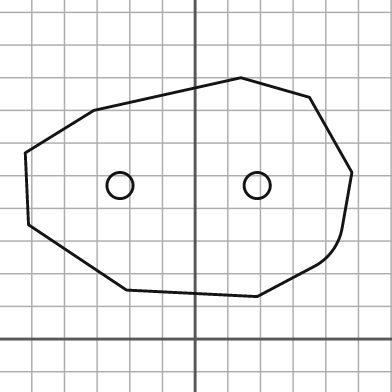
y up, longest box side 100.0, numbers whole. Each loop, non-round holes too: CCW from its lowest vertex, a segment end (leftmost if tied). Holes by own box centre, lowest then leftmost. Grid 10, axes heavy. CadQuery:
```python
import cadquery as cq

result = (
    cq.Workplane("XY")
    .moveTo(19.0, 13.0)
    .lineTo(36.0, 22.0)
    .threePointArc((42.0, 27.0), (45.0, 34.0))
    .lineTo(48.0, 51.0)
    .lineTo(35.0, 74.0)
    .lineTo(14.0, 80.0)
    .lineTo(-31.0, 70.0)
    .lineTo(-52.0, 57.0)
    .lineTo(-51.0, 35.0)
    .lineTo(-21.0, 15.0)
    .close()
    .moveTo(-23.0, 47.0)
    .circle(4.0)
    .moveTo(19.0, 47.0)
    .circle(4.0)
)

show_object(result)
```